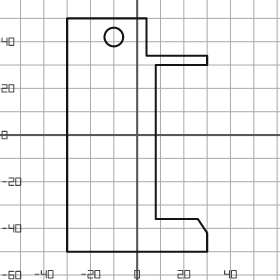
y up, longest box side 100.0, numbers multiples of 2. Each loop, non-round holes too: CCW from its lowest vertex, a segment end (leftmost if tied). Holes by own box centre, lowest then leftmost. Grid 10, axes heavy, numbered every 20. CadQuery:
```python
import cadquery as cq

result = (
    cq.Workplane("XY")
    .moveTo(-30.0, -50.0)
    .lineTo(30.0, -50.0)
    .lineTo(30.0, -42.0)
    .lineTo(26.0, -36.0)
    .lineTo(8.0, -36.0)
    .lineTo(8.0, 30.0)
    .lineTo(30.0, 30.0)
    .lineTo(30.0, 34.0)
    .lineTo(4.0, 34.0)
    .lineTo(4.0, 50.0)
    .lineTo(-30.0, 50.0)
    .close()
    .moveTo(-10.0, 42.0)
    .circle(4.0)
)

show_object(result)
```